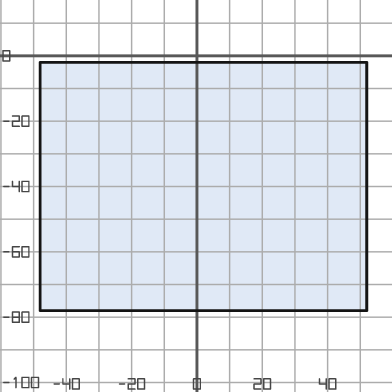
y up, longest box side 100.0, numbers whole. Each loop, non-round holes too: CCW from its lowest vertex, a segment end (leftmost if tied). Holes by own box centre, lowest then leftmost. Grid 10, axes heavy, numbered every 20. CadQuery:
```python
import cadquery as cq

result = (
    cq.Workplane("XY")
    .moveTo(-48.0, -78.0)
    .lineTo(52.0, -78.0)
    .lineTo(52.0, -2.0)
    .lineTo(-48.0, -2.0)
    .close()
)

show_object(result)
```